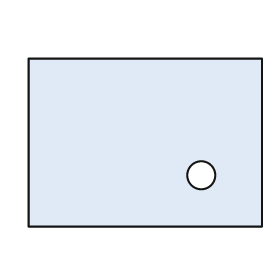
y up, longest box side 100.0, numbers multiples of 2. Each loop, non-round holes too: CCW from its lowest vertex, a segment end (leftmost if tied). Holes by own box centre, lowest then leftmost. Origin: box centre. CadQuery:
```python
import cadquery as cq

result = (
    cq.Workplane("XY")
    .moveTo(-50.0, -36.0)
    .lineTo(50.0, -36.0)
    .lineTo(50.0, 36.0)
    .lineTo(-50.0, 36.0)
    .close()
    .moveTo(24.0, -14.0)
    .circle(6.0)
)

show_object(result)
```